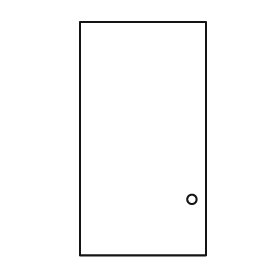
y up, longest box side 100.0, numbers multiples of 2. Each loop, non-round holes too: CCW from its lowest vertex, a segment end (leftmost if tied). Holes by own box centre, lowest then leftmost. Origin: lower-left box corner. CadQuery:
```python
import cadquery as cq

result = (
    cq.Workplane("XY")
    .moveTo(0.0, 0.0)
    .lineTo(54.0, 0.0)
    .lineTo(54.0, 100.0)
    .lineTo(0.0, 100.0)
    .close()
    .moveTo(48.0, 24.0)
    .circle(2.0)
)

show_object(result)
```